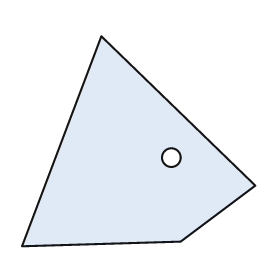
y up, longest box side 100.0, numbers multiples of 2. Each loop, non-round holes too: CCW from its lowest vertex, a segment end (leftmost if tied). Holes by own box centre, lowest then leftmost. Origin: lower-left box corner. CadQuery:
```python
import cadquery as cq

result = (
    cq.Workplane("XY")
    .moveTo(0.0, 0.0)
    .lineTo(68.0, 2.0)
    .lineTo(100.0, 26.0)
    .lineTo(34.0, 90.0)
    .close()
    .moveTo(64.0, 38.0)
    .circle(4.0)
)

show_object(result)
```